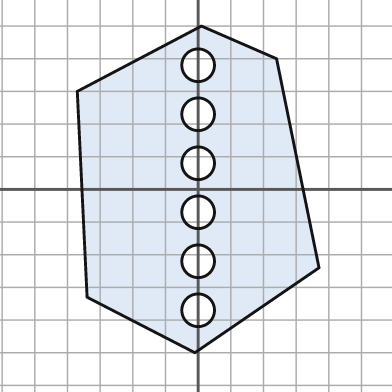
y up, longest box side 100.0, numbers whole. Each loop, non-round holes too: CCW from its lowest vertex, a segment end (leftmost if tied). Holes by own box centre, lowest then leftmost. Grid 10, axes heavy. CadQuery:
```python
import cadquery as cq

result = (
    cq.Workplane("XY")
    .moveTo(-1.0, -50.0)
    .lineTo(37.0, -24.0)
    .lineTo(24.0, 40.0)
    .lineTo(1.0, 50.0)
    .lineTo(-37.0, 30.0)
    .lineTo(-34.0, -33.0)
    .close()
    .moveTo(0.0, -37.0)
    .circle(5.0)
    .moveTo(0.0, -22.0)
    .circle(5.0)
    .moveTo(0.0, -7.0)
    .circle(5.0)
    .moveTo(0.0, 8.0)
    .circle(5.0)
    .moveTo(0.0, 23.0)
    .circle(5.0)
    .moveTo(0.0, 38.0)
    .circle(5.0)
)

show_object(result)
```